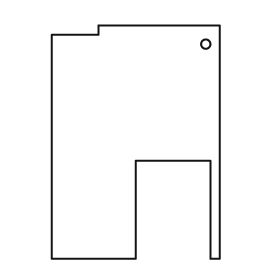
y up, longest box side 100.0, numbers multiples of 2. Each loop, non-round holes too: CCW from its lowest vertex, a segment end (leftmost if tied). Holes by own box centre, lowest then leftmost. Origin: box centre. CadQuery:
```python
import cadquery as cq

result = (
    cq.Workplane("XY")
    .moveTo(-36.0, -50.0)
    .lineTo(0.0, -50.0)
    .lineTo(0.0, -8.0)
    .lineTo(32.0, -8.0)
    .lineTo(32.0, -50.0)
    .lineTo(36.0, -50.0)
    .lineTo(36.0, 50.0)
    .lineTo(-16.0, 50.0)
    .lineTo(-16.0, 46.0)
    .lineTo(-36.0, 46.0)
    .close()
    .moveTo(30.0, 42.0)
    .circle(2.0)
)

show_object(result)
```